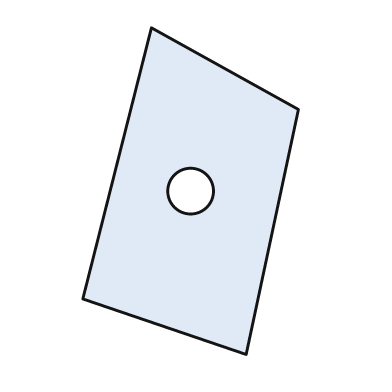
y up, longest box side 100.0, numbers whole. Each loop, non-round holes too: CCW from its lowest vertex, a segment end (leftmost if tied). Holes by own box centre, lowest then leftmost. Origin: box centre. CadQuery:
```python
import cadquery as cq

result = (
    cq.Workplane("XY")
    .moveTo(17.0, -50.0)
    .lineTo(33.0, 25.0)
    .lineTo(-12.0, 50.0)
    .lineTo(-33.0, -33.0)
    .close()
    .moveTo(0.0, 0.0)
    .circle(7.0)
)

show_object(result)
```